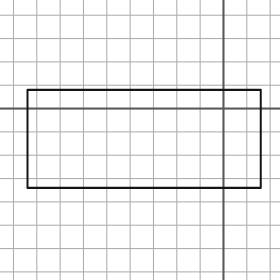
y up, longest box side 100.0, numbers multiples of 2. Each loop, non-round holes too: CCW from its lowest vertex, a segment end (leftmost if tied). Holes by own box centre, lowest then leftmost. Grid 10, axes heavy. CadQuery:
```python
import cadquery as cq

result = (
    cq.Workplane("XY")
    .moveTo(-84.0, -34.0)
    .lineTo(16.0, -34.0)
    .lineTo(16.0, 8.0)
    .lineTo(-84.0, 8.0)
    .close()
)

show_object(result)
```